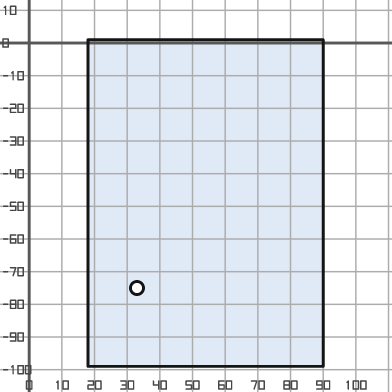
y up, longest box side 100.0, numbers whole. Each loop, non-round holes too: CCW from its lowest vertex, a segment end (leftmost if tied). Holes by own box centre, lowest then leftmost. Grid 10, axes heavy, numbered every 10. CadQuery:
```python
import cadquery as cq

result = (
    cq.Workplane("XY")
    .moveTo(18.0, -99.0)
    .lineTo(90.0, -99.0)
    .lineTo(90.0, 1.0)
    .lineTo(18.0, 1.0)
    .close()
    .moveTo(33.0, -75.0)
    .circle(2.0)
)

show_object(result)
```